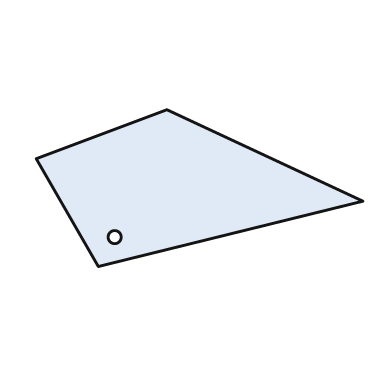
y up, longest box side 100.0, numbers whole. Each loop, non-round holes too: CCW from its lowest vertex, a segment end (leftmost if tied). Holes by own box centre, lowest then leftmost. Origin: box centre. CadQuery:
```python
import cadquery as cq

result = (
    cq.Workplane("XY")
    .moveTo(-31.0, -24.0)
    .lineTo(50.0, -4.0)
    .lineTo(-10.0, 24.0)
    .lineTo(-50.0, 9.0)
    .close()
    .moveTo(-26.0, -15.0)
    .circle(2.0)
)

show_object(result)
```